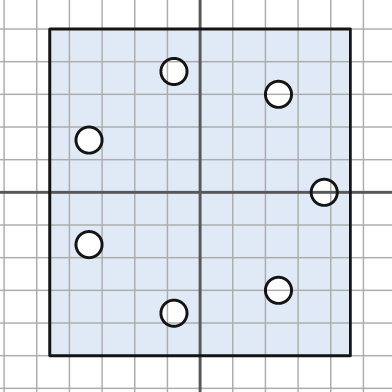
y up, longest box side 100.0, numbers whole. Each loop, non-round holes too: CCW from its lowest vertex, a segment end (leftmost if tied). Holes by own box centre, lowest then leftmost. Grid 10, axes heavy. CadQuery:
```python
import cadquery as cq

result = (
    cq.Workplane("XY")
    .moveTo(-46.0, -50.0)
    .lineTo(46.0, -50.0)
    .lineTo(46.0, 50.0)
    .lineTo(-46.0, 50.0)
    .close()
    .moveTo(-8.0, -37.0)
    .circle(4.0)
    .moveTo(24.0, -30.0)
    .circle(4.0)
    .moveTo(-34.0, -16.0)
    .circle(4.0)
    .moveTo(38.0, 0.0)
    .circle(4.0)
    .moveTo(-34.0, 16.0)
    .circle(4.0)
    .moveTo(24.0, 30.0)
    .circle(4.0)
    .moveTo(-8.0, 37.0)
    .circle(4.0)
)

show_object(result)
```